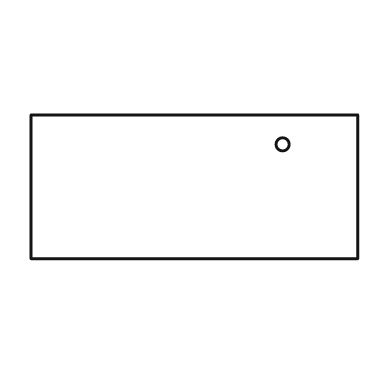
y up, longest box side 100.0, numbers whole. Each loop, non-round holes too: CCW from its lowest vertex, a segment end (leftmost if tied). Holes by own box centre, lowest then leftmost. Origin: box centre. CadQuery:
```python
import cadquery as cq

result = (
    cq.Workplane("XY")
    .moveTo(-50.0, -22.0)
    .lineTo(50.0, -22.0)
    .lineTo(50.0, 22.0)
    .lineTo(-50.0, 22.0)
    .close()
    .moveTo(27.0, 13.0)
    .circle(2.0)
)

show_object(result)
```